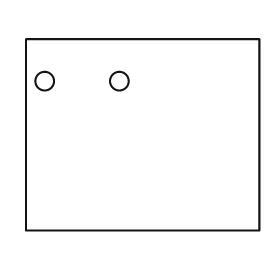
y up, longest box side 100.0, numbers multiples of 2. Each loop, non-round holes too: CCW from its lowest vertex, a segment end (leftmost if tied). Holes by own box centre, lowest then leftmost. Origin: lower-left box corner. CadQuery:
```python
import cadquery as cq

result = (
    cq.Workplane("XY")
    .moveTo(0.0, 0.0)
    .lineTo(100.0, 0.0)
    .lineTo(100.0, 82.0)
    .lineTo(0.0, 82.0)
    .close()
    .moveTo(8.0, 64.0)
    .circle(4.0)
    .moveTo(40.0, 64.0)
    .circle(4.0)
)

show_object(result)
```